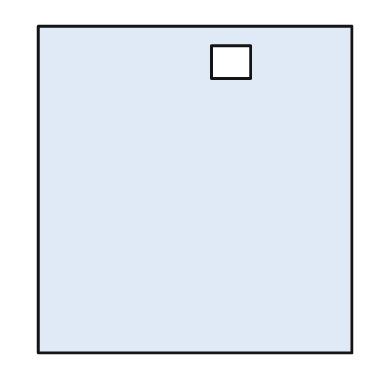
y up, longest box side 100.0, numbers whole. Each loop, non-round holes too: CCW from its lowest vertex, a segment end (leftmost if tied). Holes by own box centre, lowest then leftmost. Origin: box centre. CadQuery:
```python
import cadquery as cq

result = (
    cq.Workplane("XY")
    .moveTo(-48.0, -50.0)
    .lineTo(48.0, -50.0)
    .lineTo(48.0, 50.0)
    .lineTo(-48.0, 50.0)
    .close()
    .moveTo(5.0, 34.0)
    .lineTo(17.0, 34.0)
    .lineTo(17.0, 44.0)
    .lineTo(5.0, 44.0)
    .close()
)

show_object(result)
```